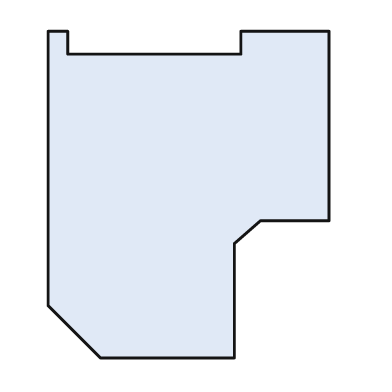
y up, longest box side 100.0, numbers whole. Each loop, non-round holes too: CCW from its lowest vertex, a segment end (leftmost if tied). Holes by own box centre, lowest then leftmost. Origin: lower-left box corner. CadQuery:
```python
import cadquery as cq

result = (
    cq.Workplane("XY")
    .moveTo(16.0, 0.0)
    .lineTo(57.0, 0.0)
    .lineTo(57.0, 35.0)
    .lineTo(65.0, 42.0)
    .lineTo(86.0, 42.0)
    .lineTo(86.0, 100.0)
    .lineTo(59.0, 100.0)
    .lineTo(59.0, 93.0)
    .lineTo(6.0, 93.0)
    .lineTo(6.0, 100.0)
    .lineTo(0.0, 100.0)
    .lineTo(0.0, 16.0)
    .close()
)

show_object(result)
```